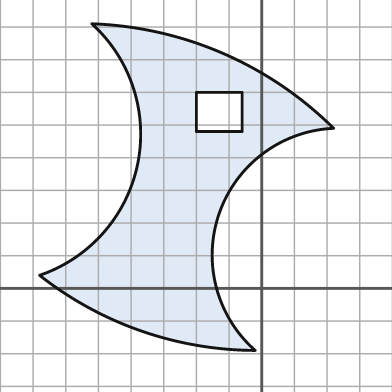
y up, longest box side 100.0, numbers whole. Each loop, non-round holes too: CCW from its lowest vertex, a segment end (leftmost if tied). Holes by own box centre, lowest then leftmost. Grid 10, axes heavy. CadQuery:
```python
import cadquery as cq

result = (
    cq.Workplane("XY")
    .moveTo(-2.0, -19.0)
    .threePointArc((-13.0, 23.0), (22.0, 49.0))
    .threePointArc((-12.0, 72.0), (-52.0, 81.0))
    .threePointArc((-38.0, 38.0), (-68.0, 4.0))
    .threePointArc((-37.0, -13.0), (-2.0, -19.0))
    .close()
    .moveTo(-20.0, 48.0)
    .lineTo(-6.0, 48.0)
    .lineTo(-6.0, 60.0)
    .lineTo(-20.0, 60.0)
    .close()
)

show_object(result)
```